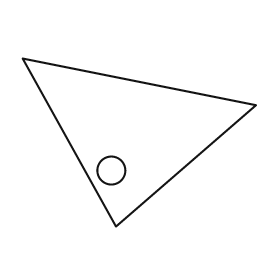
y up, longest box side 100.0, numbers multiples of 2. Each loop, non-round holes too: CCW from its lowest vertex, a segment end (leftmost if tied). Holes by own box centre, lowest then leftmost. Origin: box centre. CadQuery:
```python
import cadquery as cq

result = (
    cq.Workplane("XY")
    .moveTo(-10.0, -36.0)
    .lineTo(50.0, 16.0)
    .lineTo(-50.0, 36.0)
    .close()
    .moveTo(-12.0, -12.0)
    .circle(6.0)
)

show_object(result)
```